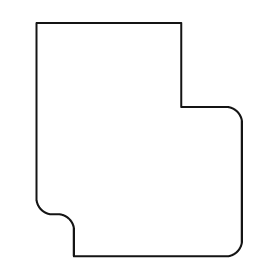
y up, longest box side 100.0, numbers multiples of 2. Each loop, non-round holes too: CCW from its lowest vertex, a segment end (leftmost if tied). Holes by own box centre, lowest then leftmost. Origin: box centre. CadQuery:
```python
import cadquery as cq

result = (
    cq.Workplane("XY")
    .moveTo(-28.0, -50.0)
    .lineTo(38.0, -50.0)
    .threePointArc((42.0, -48.0), (44.0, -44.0))
    .lineTo(44.0, 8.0)
    .threePointArc((42.0, 12.0), (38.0, 14.0))
    .lineTo(18.0, 14.0)
    .lineTo(18.0, 50.0)
    .lineTo(-44.0, 50.0)
    .lineTo(-44.0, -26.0)
    .threePointArc((-42.0, -30.0), (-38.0, -32.0))
    .lineTo(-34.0, -32.0)
    .threePointArc((-30.0, -34.0), (-28.0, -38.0))
    .close()
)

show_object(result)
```